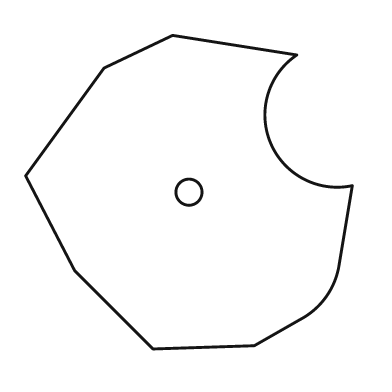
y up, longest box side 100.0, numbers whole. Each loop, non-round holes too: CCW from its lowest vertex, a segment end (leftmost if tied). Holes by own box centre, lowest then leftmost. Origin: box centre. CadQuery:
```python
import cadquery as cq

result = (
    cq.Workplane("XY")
    .moveTo(-11.0, -48.0)
    .lineTo(20.0, -47.0)
    .lineTo(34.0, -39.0)
    .threePointArc((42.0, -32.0), (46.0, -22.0))
    .lineTo(50.0, 2.0)
    .threePointArc((25.0, 15.0), (33.0, 42.0))
    .lineTo(-5.0, 48.0)
    .lineTo(-26.0, 38.0)
    .lineTo(-50.0, 5.0)
    .lineTo(-35.0, -24.0)
    .close()
    .moveTo(0.0, 0.0)
    .circle(4.0)
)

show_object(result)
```